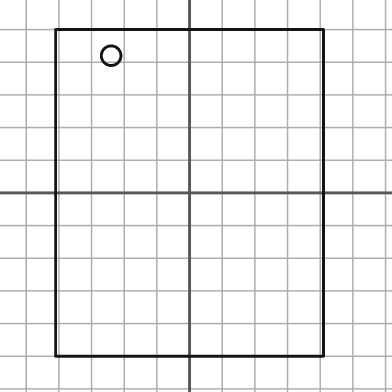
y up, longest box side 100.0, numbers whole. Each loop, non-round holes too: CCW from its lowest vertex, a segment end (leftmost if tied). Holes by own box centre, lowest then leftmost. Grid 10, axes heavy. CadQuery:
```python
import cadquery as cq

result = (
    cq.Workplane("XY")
    .moveTo(-41.0, -50.0)
    .lineTo(41.0, -50.0)
    .lineTo(41.0, 50.0)
    .lineTo(-41.0, 50.0)
    .close()
    .moveTo(-24.0, 42.0)
    .circle(3.0)
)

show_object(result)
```